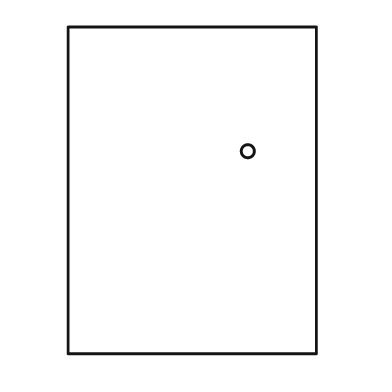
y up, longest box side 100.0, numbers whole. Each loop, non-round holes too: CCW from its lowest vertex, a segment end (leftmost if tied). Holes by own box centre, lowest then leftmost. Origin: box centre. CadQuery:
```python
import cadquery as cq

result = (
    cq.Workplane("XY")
    .moveTo(-38.0, -50.0)
    .lineTo(38.0, -50.0)
    .lineTo(38.0, 50.0)
    .lineTo(-38.0, 50.0)
    .close()
    .moveTo(17.0, 12.0)
    .circle(2.0)
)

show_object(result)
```